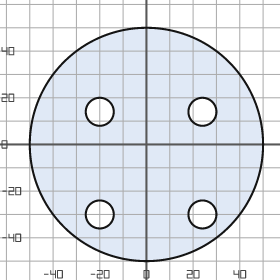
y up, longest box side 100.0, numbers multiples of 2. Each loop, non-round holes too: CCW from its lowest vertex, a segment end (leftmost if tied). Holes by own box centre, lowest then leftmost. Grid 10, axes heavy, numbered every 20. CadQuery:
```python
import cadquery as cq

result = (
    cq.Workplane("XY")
    .moveTo(0.0, 0.0)
    .circle(50.0)
    .moveTo(-20.0, -30.0)
    .circle(6.0)
    .moveTo(24.0, -30.0)
    .circle(6.0)
    .moveTo(-20.0, 14.0)
    .circle(6.0)
    .moveTo(24.0, 14.0)
    .circle(6.0)
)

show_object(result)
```